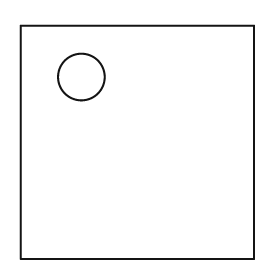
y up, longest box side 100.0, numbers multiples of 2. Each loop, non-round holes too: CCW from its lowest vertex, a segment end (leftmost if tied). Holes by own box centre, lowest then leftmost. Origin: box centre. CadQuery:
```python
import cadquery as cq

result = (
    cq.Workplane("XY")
    .moveTo(-50.0, -50.0)
    .lineTo(50.0, -50.0)
    .lineTo(50.0, 50.0)
    .lineTo(-50.0, 50.0)
    .close()
    .moveTo(-24.0, 28.0)
    .circle(10.0)
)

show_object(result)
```